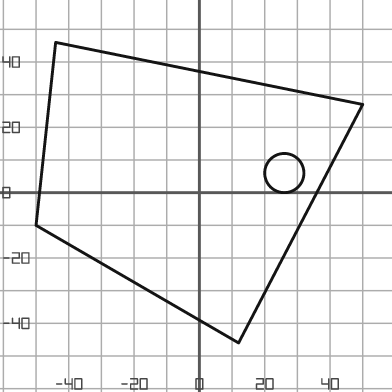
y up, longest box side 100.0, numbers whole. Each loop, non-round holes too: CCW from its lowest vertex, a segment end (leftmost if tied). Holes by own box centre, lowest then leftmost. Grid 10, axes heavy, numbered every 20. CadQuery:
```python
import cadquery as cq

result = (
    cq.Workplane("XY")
    .moveTo(12.0, -46.0)
    .lineTo(50.0, 27.0)
    .lineTo(-44.0, 46.0)
    .lineTo(-50.0, -10.0)
    .close()
    .moveTo(26.0, 6.0)
    .circle(6.0)
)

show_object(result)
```